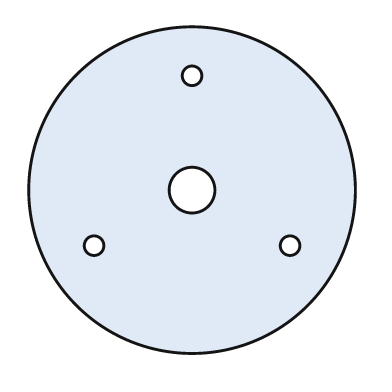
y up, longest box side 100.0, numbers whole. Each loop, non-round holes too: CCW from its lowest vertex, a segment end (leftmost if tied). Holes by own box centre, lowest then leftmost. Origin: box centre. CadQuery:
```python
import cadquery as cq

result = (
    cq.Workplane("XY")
    .moveTo(0.0, 0.0)
    .circle(50.0)
    .moveTo(-30.0, -17.0)
    .circle(3.0)
    .moveTo(30.0, -17.0)
    .circle(3.0)
    .moveTo(0.0, 0.0)
    .circle(7.0)
    .moveTo(0.0, 35.0)
    .circle(3.0)
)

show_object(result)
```